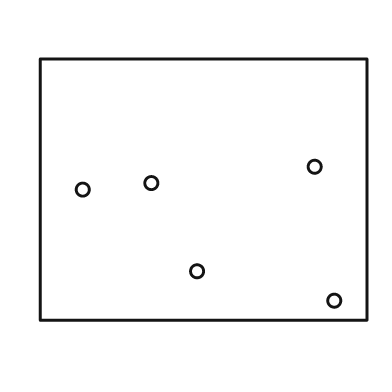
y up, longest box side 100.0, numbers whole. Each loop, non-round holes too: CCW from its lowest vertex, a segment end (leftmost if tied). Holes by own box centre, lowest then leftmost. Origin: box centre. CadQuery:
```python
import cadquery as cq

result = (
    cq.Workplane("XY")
    .moveTo(-50.0, -40.0)
    .lineTo(50.0, -40.0)
    .lineTo(50.0, 40.0)
    .lineTo(-50.0, 40.0)
    .close()
    .moveTo(40.0, -34.0)
    .circle(2.0)
    .moveTo(-2.0, -25.0)
    .circle(2.0)
    .moveTo(-37.0, 0.0)
    .circle(2.0)
    .moveTo(-16.0, 2.0)
    .circle(2.0)
    .moveTo(34.0, 7.0)
    .circle(2.0)
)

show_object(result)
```